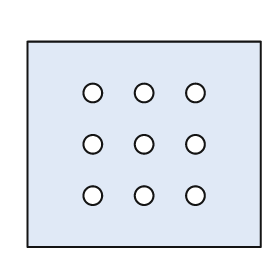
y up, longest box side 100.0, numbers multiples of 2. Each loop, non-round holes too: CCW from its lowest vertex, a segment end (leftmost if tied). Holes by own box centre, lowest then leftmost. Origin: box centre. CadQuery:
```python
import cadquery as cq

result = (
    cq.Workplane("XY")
    .moveTo(-50.0, -44.0)
    .lineTo(50.0, -44.0)
    .lineTo(50.0, 44.0)
    .lineTo(-50.0, 44.0)
    .close()
    .moveTo(-22.0, -22.0)
    .circle(4.0)
    .moveTo(0.0, -22.0)
    .circle(4.0)
    .moveTo(22.0, -22.0)
    .circle(4.0)
    .moveTo(-22.0, 0.0)
    .circle(4.0)
    .moveTo(0.0, 0.0)
    .circle(4.0)
    .moveTo(22.0, 0.0)
    .circle(4.0)
    .moveTo(-22.0, 22.0)
    .circle(4.0)
    .moveTo(0.0, 22.0)
    .circle(4.0)
    .moveTo(22.0, 22.0)
    .circle(4.0)
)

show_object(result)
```